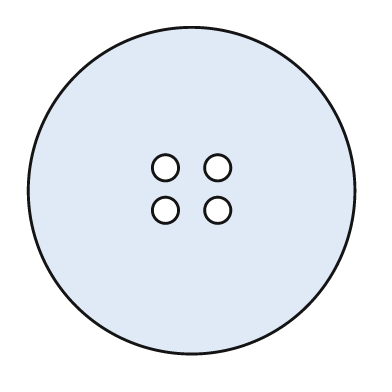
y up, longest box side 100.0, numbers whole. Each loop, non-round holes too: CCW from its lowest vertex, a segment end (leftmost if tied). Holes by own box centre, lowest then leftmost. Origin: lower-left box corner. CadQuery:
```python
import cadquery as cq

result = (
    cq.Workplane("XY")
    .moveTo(50.0, 50.0)
    .circle(50.0)
    .moveTo(42.0, 44.0)
    .circle(4.0)
    .moveTo(58.0, 44.0)
    .circle(4.0)
    .moveTo(42.0, 57.0)
    .circle(4.0)
    .moveTo(58.0, 57.0)
    .circle(4.0)
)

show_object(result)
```